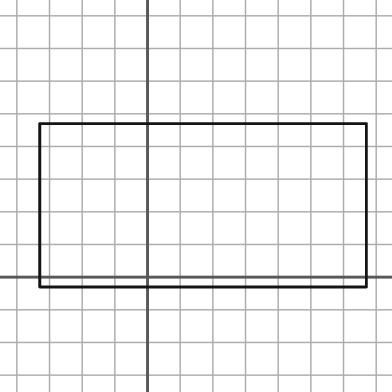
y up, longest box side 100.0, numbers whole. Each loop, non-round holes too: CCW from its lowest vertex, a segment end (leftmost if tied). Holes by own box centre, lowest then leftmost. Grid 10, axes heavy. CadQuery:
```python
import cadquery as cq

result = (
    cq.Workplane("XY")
    .moveTo(-33.0, -3.0)
    .lineTo(67.0, -3.0)
    .lineTo(67.0, 47.0)
    .lineTo(-33.0, 47.0)
    .close()
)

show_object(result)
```